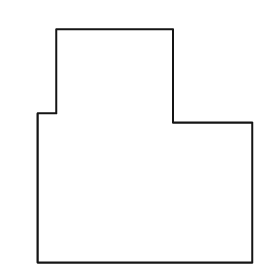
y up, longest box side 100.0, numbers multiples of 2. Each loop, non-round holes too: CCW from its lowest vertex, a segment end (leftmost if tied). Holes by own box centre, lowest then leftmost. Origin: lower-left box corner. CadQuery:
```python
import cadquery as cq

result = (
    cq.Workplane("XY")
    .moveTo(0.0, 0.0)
    .lineTo(92.0, 0.0)
    .lineTo(92.0, 60.0)
    .lineTo(58.0, 60.0)
    .lineTo(58.0, 100.0)
    .lineTo(8.0, 100.0)
    .lineTo(8.0, 64.0)
    .lineTo(0.0, 64.0)
    .close()
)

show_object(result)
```